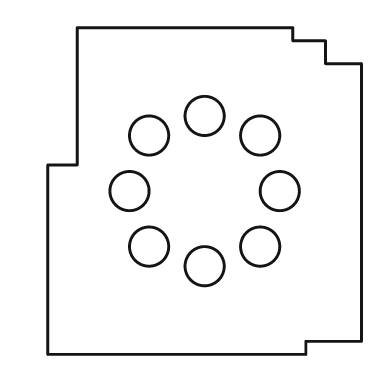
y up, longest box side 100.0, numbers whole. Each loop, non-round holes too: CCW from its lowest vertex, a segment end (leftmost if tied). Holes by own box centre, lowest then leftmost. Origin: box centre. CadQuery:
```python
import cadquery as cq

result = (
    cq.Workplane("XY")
    .moveTo(-48.0, -50.0)
    .lineTo(31.0, -50.0)
    .lineTo(31.0, -46.0)
    .lineTo(48.0, -46.0)
    .lineTo(48.0, 39.0)
    .lineTo(37.0, 39.0)
    .lineTo(37.0, 46.0)
    .lineTo(27.0, 46.0)
    .lineTo(27.0, 50.0)
    .lineTo(-39.0, 50.0)
    .lineTo(-39.0, 8.0)
    .lineTo(-48.0, 8.0)
    .close()
    .moveTo(0.0, -23.0)
    .circle(6.0)
    .moveTo(-17.0, -17.0)
    .circle(6.0)
    .moveTo(17.0, -17.0)
    .circle(6.0)
    .moveTo(-23.0, 0.0)
    .circle(6.0)
    .moveTo(23.0, 0.0)
    .circle(6.0)
    .moveTo(-17.0, 17.0)
    .circle(6.0)
    .moveTo(17.0, 17.0)
    .circle(6.0)
    .moveTo(0.0, 23.0)
    .circle(6.0)
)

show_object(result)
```